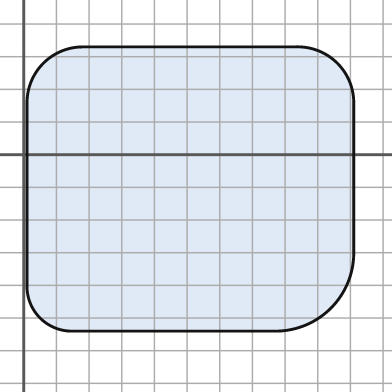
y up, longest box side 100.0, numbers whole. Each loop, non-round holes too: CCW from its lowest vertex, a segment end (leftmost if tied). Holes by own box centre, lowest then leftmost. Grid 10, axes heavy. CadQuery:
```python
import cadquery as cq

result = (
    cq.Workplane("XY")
    .moveTo(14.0, -54.0)
    .lineTo(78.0, -54.0)
    .threePointArc((94.0, -47.0), (101.0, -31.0))
    .lineTo(101.0, 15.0)
    .threePointArc((96.0, 28.0), (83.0, 33.0))
    .lineTo(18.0, 33.0)
    .threePointArc((6.0, 28.0), (1.0, 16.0))
    .lineTo(1.0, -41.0)
    .threePointArc((5.0, -50.0), (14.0, -54.0))
    .close()
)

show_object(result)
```